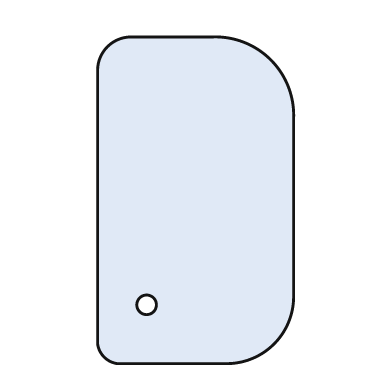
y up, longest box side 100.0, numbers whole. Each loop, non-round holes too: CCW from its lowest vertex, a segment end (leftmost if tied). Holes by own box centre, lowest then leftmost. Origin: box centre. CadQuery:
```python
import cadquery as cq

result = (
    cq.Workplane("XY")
    .moveTo(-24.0, -50.0)
    .lineTo(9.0, -50.0)
    .threePointArc((24.0, -44.0), (30.0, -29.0))
    .lineTo(30.0, 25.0)
    .threePointArc((23.0, 43.0), (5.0, 50.0))
    .lineTo(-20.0, 50.0)
    .threePointArc((-27.0, 47.0), (-30.0, 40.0))
    .lineTo(-30.0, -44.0)
    .threePointArc((-28.0, -48.0), (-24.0, -50.0))
    .close()
    .moveTo(-15.0, -32.0)
    .circle(3.0)
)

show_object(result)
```